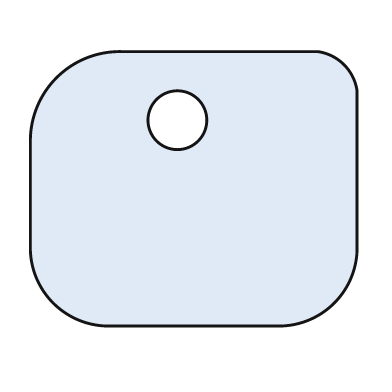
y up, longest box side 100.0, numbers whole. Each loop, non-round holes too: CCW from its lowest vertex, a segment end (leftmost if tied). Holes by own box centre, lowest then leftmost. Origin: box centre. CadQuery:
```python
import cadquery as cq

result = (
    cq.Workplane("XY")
    .moveTo(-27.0, -42.0)
    .lineTo(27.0, -42.0)
    .threePointArc((43.0, -35.0), (50.0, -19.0))
    .lineTo(50.0, 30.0)
    .threePointArc((46.0, 38.0), (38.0, 42.0))
    .lineTo(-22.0, 42.0)
    .threePointArc((-42.0, 34.0), (-50.0, 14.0))
    .lineTo(-50.0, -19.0)
    .threePointArc((-43.0, -35.0), (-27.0, -42.0))
    .close()
    .moveTo(-5.0, 21.0)
    .circle(9.0)
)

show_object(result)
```